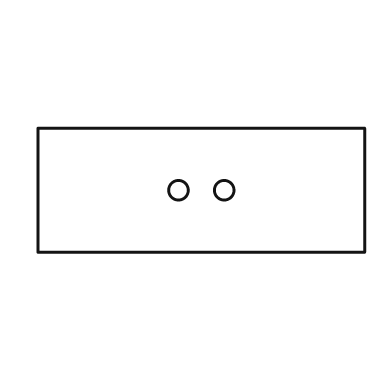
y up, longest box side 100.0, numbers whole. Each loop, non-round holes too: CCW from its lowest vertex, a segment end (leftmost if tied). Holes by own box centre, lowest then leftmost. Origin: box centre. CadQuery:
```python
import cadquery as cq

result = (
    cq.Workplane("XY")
    .moveTo(-50.0, -19.0)
    .lineTo(50.0, -19.0)
    .lineTo(50.0, 19.0)
    .lineTo(-50.0, 19.0)
    .close()
    .moveTo(-7.0, 0.0)
    .circle(3.0)
    .moveTo(7.0, 0.0)
    .circle(3.0)
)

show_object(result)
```